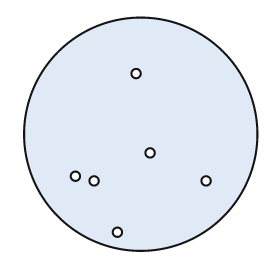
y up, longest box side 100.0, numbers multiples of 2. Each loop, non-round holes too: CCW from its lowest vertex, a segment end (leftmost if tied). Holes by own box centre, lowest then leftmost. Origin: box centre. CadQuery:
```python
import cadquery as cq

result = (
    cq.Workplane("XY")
    .moveTo(0.0, 0.0)
    .circle(50.0)
    .moveTo(-10.0, -42.0)
    .circle(2.0)
    .moveTo(-20.0, -20.0)
    .circle(2.0)
    .moveTo(28.0, -20.0)
    .circle(2.0)
    .moveTo(-28.0, -18.0)
    .circle(2.0)
    .moveTo(4.0, -8.0)
    .circle(2.0)
    .moveTo(-2.0, 26.0)
    .circle(2.0)
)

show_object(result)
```